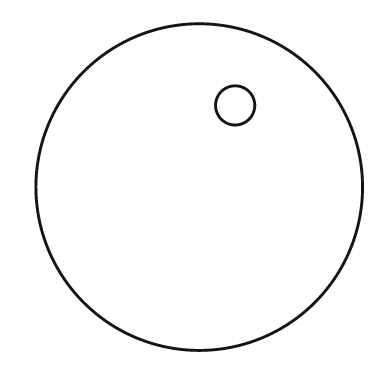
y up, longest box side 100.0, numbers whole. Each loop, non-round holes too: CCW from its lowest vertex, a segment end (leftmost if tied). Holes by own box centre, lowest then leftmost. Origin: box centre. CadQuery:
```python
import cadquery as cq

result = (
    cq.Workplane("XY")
    .moveTo(0.0, 0.0)
    .circle(50.0)
    .moveTo(11.0, 25.0)
    .circle(6.0)
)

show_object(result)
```